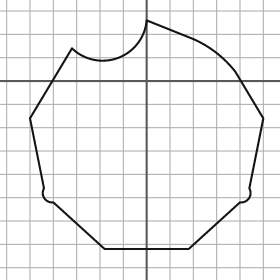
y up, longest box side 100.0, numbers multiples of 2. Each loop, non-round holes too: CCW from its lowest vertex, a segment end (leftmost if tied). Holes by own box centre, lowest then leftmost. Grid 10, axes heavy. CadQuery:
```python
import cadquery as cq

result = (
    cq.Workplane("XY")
    .moveTo(-18.0, -72.0)
    .lineTo(18.0, -72.0)
    .lineTo(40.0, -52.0)
    .threePointArc((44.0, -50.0), (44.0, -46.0))
    .lineTo(50.0, -16.0)
    .lineTo(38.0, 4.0)
    .threePointArc((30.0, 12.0), (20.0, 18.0))
    .lineTo(0.0, 26.0)
    .threePointArc((-12.0, 10.0), (-32.0, 14.0))
    .lineTo(-50.0, -16.0)
    .lineTo(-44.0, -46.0)
    .threePointArc((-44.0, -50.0), (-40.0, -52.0))
    .close()
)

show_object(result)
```